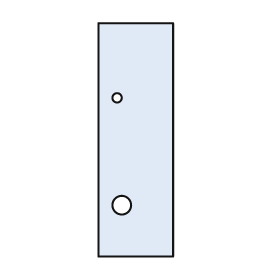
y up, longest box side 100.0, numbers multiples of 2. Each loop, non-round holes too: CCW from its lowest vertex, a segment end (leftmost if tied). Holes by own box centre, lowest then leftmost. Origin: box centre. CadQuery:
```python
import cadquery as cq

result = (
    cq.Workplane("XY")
    .moveTo(-16.0, -50.0)
    .lineTo(16.0, -50.0)
    .lineTo(16.0, 50.0)
    .lineTo(-16.0, 50.0)
    .close()
    .moveTo(-6.0, -28.0)
    .circle(4.0)
    .moveTo(-8.0, 18.0)
    .circle(2.0)
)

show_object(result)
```